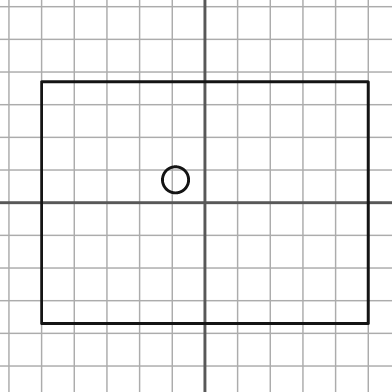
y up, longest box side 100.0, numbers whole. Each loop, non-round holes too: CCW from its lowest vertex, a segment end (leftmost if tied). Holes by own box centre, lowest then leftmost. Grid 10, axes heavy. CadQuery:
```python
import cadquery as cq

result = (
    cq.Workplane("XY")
    .moveTo(-50.0, -37.0)
    .lineTo(50.0, -37.0)
    .lineTo(50.0, 37.0)
    .lineTo(-50.0, 37.0)
    .close()
    .moveTo(-9.0, 7.0)
    .circle(4.0)
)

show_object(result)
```